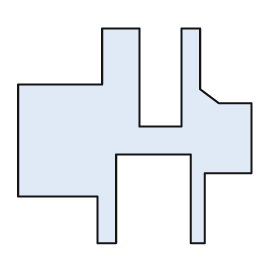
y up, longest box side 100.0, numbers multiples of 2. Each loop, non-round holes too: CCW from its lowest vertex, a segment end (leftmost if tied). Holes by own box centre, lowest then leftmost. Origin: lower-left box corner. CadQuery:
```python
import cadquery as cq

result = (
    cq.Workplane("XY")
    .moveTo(34.0, 0.0)
    .lineTo(42.0, 0.0)
    .lineTo(42.0, 38.0)
    .lineTo(74.0, 38.0)
    .lineTo(74.0, 0.0)
    .lineTo(80.0, 0.0)
    .lineTo(80.0, 30.0)
    .lineTo(100.0, 30.0)
    .lineTo(100.0, 60.0)
    .lineTo(86.0, 60.0)
    .lineTo(78.0, 66.0)
    .lineTo(78.0, 92.0)
    .lineTo(70.0, 92.0)
    .lineTo(70.0, 50.0)
    .lineTo(52.0, 50.0)
    .lineTo(52.0, 92.0)
    .lineTo(36.0, 92.0)
    .lineTo(36.0, 68.0)
    .lineTo(0.0, 68.0)
    .lineTo(0.0, 20.0)
    .lineTo(34.0, 20.0)
    .close()
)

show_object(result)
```